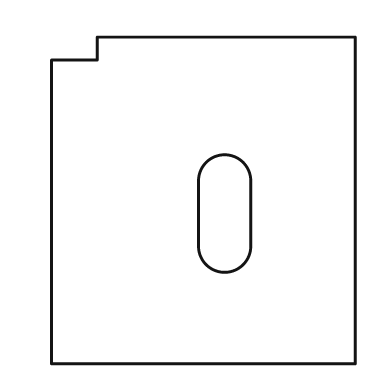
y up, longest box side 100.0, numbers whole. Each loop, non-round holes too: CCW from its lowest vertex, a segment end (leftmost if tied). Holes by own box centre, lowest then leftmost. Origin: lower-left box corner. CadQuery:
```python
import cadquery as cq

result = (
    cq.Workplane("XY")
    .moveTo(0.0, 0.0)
    .lineTo(93.0, 0.0)
    .lineTo(93.0, 100.0)
    .lineTo(14.0, 100.0)
    .lineTo(14.0, 93.0)
    .lineTo(0.0, 93.0)
    .close()
    .moveTo(45.0, 36.0)
    .threePointArc((53.0, 28.0), (61.0, 36.0))
    .lineTo(61.0, 56.0)
    .threePointArc((53.0, 64.0), (45.0, 56.0))
    .close()
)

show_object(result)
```